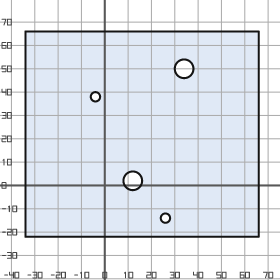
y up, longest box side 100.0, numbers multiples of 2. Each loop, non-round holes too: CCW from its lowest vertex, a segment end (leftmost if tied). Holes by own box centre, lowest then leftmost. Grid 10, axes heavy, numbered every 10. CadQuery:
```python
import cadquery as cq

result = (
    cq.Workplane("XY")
    .moveTo(-34.0, -22.0)
    .lineTo(66.0, -22.0)
    .lineTo(66.0, 66.0)
    .lineTo(-34.0, 66.0)
    .close()
    .moveTo(26.0, -14.0)
    .circle(2.0)
    .moveTo(12.0, 2.0)
    .circle(4.0)
    .moveTo(-4.0, 38.0)
    .circle(2.0)
    .moveTo(34.0, 50.0)
    .circle(4.0)
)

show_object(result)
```